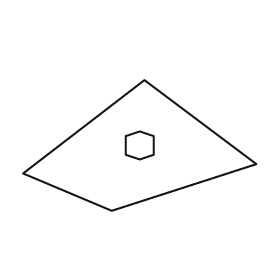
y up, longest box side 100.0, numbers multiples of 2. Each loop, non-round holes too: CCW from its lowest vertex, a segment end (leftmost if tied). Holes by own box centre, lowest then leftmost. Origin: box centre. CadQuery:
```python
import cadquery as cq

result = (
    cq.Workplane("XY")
    .moveTo(-12.0, -28.0)
    .lineTo(50.0, -8.0)
    .lineTo(2.0, 28.0)
    .lineTo(-50.0, -12.0)
    .close()
    .moveTo(0.0, -6.0)
    .lineTo(6.0, -4.0)
    .lineTo(6.0, 4.0)
    .lineTo(0.0, 6.0)
    .lineTo(-6.0, 4.0)
    .lineTo(-6.0, -4.0)
    .close()
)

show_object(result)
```